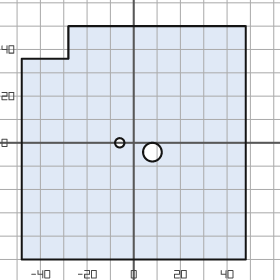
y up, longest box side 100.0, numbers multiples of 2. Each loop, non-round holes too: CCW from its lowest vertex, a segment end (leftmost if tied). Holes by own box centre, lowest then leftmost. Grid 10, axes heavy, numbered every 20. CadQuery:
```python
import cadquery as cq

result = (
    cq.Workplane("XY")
    .moveTo(-48.0, -50.0)
    .lineTo(48.0, -50.0)
    .lineTo(48.0, 50.0)
    .lineTo(-28.0, 50.0)
    .lineTo(-28.0, 36.0)
    .lineTo(-48.0, 36.0)
    .close()
    .moveTo(8.0, -4.0)
    .circle(4.0)
    .moveTo(-6.0, 0.0)
    .circle(2.0)
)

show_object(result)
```